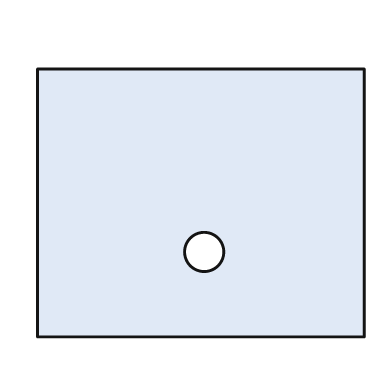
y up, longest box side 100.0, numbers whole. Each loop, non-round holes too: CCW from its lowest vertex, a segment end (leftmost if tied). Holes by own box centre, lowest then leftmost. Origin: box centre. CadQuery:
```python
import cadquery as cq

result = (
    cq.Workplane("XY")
    .moveTo(-50.0, -41.0)
    .lineTo(50.0, -41.0)
    .lineTo(50.0, 41.0)
    .lineTo(-50.0, 41.0)
    .close()
    .moveTo(1.0, -15.0)
    .circle(6.0)
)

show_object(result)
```